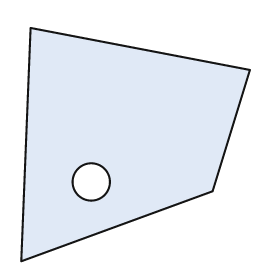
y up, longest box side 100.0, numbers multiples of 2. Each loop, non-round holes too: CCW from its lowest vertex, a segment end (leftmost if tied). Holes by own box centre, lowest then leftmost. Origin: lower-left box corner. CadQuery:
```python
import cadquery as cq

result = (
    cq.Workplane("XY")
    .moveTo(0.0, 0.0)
    .lineTo(82.0, 30.0)
    .lineTo(98.0, 82.0)
    .lineTo(4.0, 100.0)
    .close()
    .moveTo(30.0, 34.0)
    .circle(8.0)
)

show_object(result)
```